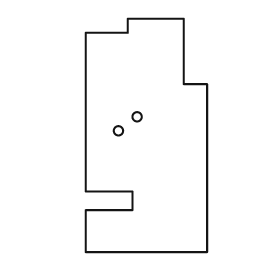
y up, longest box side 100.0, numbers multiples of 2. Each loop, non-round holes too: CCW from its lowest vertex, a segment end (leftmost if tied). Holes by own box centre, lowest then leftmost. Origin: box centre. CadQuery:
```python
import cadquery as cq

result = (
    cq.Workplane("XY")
    .moveTo(-26.0, -50.0)
    .lineTo(26.0, -50.0)
    .lineTo(26.0, 22.0)
    .lineTo(16.0, 22.0)
    .lineTo(16.0, 50.0)
    .lineTo(-8.0, 50.0)
    .lineTo(-8.0, 44.0)
    .lineTo(-26.0, 44.0)
    .lineTo(-26.0, -24.0)
    .lineTo(-6.0, -24.0)
    .lineTo(-6.0, -32.0)
    .lineTo(-26.0, -32.0)
    .close()
    .moveTo(-12.0, 2.0)
    .circle(2.0)
    .moveTo(-4.0, 8.0)
    .circle(2.0)
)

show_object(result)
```